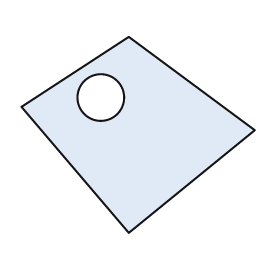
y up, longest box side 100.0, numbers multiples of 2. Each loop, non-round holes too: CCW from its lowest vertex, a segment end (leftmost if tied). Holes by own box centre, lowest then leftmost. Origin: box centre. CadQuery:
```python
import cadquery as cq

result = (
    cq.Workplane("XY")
    .moveTo(-4.0, -42.0)
    .lineTo(50.0, 2.0)
    .lineTo(-4.0, 42.0)
    .lineTo(-50.0, 12.0)
    .close()
    .moveTo(-16.0, 16.0)
    .circle(10.0)
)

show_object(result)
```